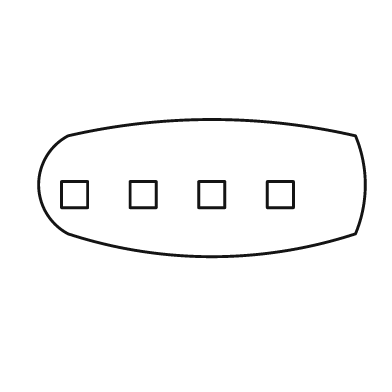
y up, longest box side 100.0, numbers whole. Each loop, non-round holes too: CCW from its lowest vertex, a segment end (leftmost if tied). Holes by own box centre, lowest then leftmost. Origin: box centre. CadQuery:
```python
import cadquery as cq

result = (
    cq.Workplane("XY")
    .moveTo(-41.0, -14.0)
    .threePointArc((3.0, -21.0), (47.0, -14.0))
    .threePointArc((50.0, 1.0), (47.0, 16.0))
    .threePointArc((3.0, 21.0), (-41.0, 16.0))
    .threePointArc((-50.0, 1.0), (-41.0, -14.0))
    .close()
    .moveTo(-43.0, -6.0)
    .lineTo(-35.0, -6.0)
    .lineTo(-35.0, 2.0)
    .lineTo(-43.0, 2.0)
    .close()
    .moveTo(-22.0, -6.0)
    .lineTo(-14.0, -6.0)
    .lineTo(-14.0, 2.0)
    .lineTo(-22.0, 2.0)
    .close()
    .moveTo(-1.0, -6.0)
    .lineTo(7.0, -6.0)
    .lineTo(7.0, 2.0)
    .lineTo(-1.0, 2.0)
    .close()
    .moveTo(20.0, -6.0)
    .lineTo(28.0, -6.0)
    .lineTo(28.0, 2.0)
    .lineTo(20.0, 2.0)
    .close()
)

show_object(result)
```